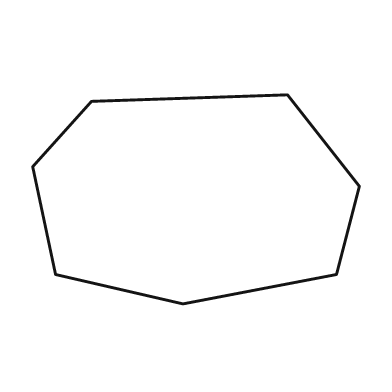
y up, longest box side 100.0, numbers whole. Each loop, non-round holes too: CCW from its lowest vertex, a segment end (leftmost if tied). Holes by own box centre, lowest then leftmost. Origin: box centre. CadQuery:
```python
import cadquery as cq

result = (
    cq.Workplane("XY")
    .moveTo(-4.0, -32.0)
    .lineTo(43.0, -23.0)
    .lineTo(50.0, 4.0)
    .lineTo(28.0, 32.0)
    .lineTo(-32.0, 30.0)
    .lineTo(-50.0, 10.0)
    .lineTo(-43.0, -23.0)
    .close()
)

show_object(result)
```